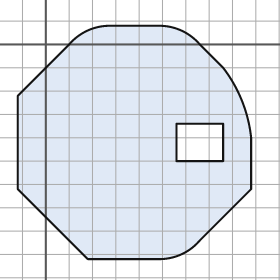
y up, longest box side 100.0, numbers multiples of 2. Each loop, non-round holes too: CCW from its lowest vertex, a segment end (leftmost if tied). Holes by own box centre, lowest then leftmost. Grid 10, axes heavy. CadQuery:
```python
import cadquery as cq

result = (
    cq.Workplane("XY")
    .moveTo(18.0, -92.0)
    .lineTo(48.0, -92.0)
    .threePointArc((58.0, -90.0), (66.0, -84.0))
    .lineTo(88.0, -62.0)
    .lineTo(88.0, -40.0)
    .threePointArc((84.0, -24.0), (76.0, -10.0))
    .lineTo(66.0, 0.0)
    .threePointArc((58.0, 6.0), (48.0, 8.0))
    .lineTo(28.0, 8.0)
    .threePointArc((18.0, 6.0), (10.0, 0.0))
    .lineTo(-12.0, -22.0)
    .lineTo(-12.0, -62.0)
    .close()
    .moveTo(56.0, -50.0)
    .lineTo(76.0, -50.0)
    .lineTo(76.0, -34.0)
    .lineTo(56.0, -34.0)
    .close()
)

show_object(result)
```